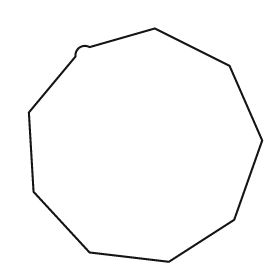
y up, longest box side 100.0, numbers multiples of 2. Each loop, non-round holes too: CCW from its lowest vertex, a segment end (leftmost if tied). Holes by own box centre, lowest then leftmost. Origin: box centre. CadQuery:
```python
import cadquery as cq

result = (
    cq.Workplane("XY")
    .moveTo(10.0, -50.0)
    .lineTo(38.0, -32.0)
    .lineTo(50.0, 2.0)
    .lineTo(36.0, 34.0)
    .lineTo(4.0, 50.0)
    .lineTo(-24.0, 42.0)
    .threePointArc((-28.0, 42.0), (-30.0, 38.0))
    .lineTo(-50.0, 14.0)
    .lineTo(-48.0, -20.0)
    .lineTo(-24.0, -46.0)
    .close()
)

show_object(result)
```